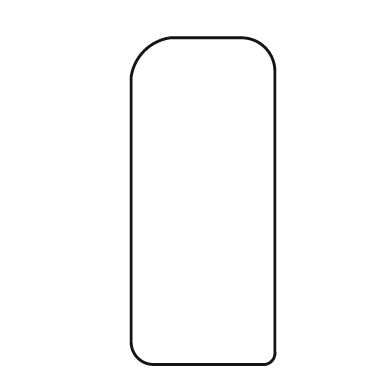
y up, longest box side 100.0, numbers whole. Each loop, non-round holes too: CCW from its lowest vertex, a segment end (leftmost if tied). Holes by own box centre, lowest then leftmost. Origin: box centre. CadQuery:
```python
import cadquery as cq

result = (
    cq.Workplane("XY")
    .moveTo(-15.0, -50.0)
    .lineTo(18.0, -50.0)
    .threePointArc((21.0, -49.0), (22.0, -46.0))
    .lineTo(22.0, 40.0)
    .threePointArc((19.0, 47.0), (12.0, 50.0))
    .lineTo(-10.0, 50.0)
    .threePointArc((-18.0, 46.0), (-22.0, 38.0))
    .lineTo(-22.0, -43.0)
    .threePointArc((-20.0, -48.0), (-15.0, -50.0))
    .close()
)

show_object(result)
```